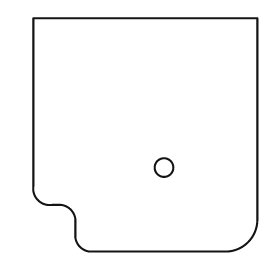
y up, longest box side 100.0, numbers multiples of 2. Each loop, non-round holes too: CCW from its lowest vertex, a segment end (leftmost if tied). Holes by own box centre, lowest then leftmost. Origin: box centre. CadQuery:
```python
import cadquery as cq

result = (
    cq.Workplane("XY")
    .moveTo(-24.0, -50.0)
    .lineTo(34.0, -50.0)
    .threePointArc((44.0, -46.0), (48.0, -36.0))
    .lineTo(48.0, 50.0)
    .lineTo(-48.0, 50.0)
    .lineTo(-48.0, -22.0)
    .threePointArc((-46.0, -28.0), (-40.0, -30.0))
    .lineTo(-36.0, -30.0)
    .threePointArc((-32.0, -32.0), (-30.0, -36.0))
    .lineTo(-30.0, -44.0)
    .threePointArc((-28.0, -48.0), (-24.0, -50.0))
    .close()
    .moveTo(8.0, -14.0)
    .circle(4.0)
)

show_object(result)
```